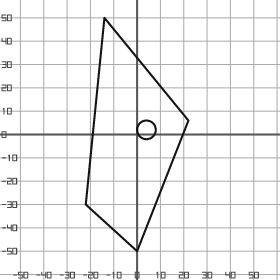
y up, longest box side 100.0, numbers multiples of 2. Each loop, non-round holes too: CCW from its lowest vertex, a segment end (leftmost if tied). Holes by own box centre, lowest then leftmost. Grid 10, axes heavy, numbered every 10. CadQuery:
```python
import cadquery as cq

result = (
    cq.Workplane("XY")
    .moveTo(0.0, -50.0)
    .lineTo(22.0, 6.0)
    .lineTo(-14.0, 50.0)
    .lineTo(-22.0, -30.0)
    .close()
    .moveTo(4.0, 2.0)
    .circle(4.0)
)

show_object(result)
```